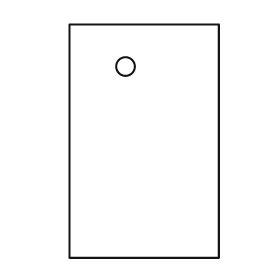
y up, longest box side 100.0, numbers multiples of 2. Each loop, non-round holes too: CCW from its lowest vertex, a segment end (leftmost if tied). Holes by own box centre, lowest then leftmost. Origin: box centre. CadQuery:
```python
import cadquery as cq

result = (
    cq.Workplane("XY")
    .moveTo(-32.0, -50.0)
    .lineTo(32.0, -50.0)
    .lineTo(32.0, 50.0)
    .lineTo(-32.0, 50.0)
    .close()
    .moveTo(-8.0, 32.0)
    .circle(4.0)
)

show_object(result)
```